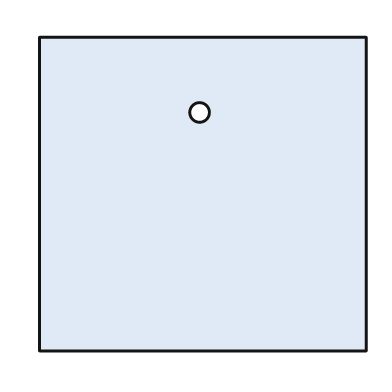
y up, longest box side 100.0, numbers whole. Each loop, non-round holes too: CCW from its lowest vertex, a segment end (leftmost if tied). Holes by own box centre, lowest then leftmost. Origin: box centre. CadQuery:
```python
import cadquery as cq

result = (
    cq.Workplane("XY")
    .moveTo(-50.0, -48.0)
    .lineTo(50.0, -48.0)
    .lineTo(50.0, 48.0)
    .lineTo(-50.0, 48.0)
    .close()
    .moveTo(-1.0, 25.0)
    .circle(3.0)
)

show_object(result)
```